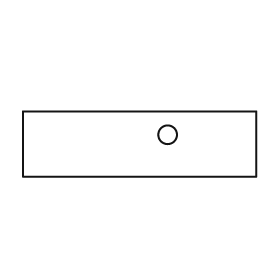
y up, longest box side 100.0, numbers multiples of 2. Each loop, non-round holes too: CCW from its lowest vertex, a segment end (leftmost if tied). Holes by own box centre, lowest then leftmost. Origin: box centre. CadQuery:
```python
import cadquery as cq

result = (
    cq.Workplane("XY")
    .moveTo(-50.0, -14.0)
    .lineTo(50.0, -14.0)
    .lineTo(50.0, 14.0)
    .lineTo(-50.0, 14.0)
    .close()
    .moveTo(12.0, 4.0)
    .circle(4.0)
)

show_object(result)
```